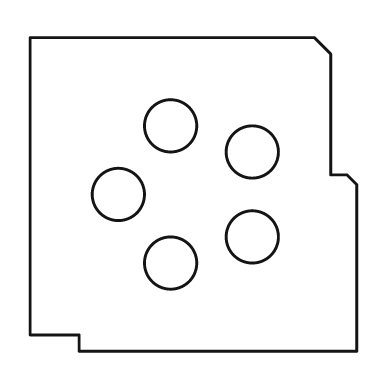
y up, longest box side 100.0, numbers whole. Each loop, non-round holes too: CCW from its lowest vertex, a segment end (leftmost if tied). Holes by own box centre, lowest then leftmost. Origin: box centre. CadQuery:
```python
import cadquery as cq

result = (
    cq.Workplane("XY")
    .moveTo(-35.0, -48.0)
    .lineTo(50.0, -48.0)
    .lineTo(50.0, 3.0)
    .lineTo(47.0, 6.0)
    .lineTo(42.0, 6.0)
    .lineTo(42.0, 43.0)
    .lineTo(37.0, 48.0)
    .lineTo(-50.0, 48.0)
    .lineTo(-50.0, -43.0)
    .lineTo(-35.0, -43.0)
    .close()
    .moveTo(-7.0, -21.0)
    .circle(8.0)
    .moveTo(18.0, -13.0)
    .circle(8.0)
    .moveTo(-23.0, 0.0)
    .circle(8.0)
    .moveTo(18.0, 13.0)
    .circle(8.0)
    .moveTo(-7.0, 21.0)
    .circle(8.0)
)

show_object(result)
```